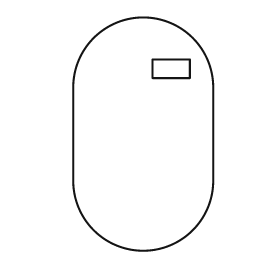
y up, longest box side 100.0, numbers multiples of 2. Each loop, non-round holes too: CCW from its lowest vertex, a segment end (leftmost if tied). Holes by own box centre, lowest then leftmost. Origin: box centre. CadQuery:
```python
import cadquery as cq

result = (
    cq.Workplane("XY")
    .moveTo(-30.0, -20.0)
    .threePointArc((0.0, -50.0), (30.0, -20.0))
    .lineTo(30.0, 20.0)
    .threePointArc((0.0, 50.0), (-30.0, 20.0))
    .close()
    .moveTo(4.0, 24.0)
    .lineTo(20.0, 24.0)
    .lineTo(20.0, 32.0)
    .lineTo(4.0, 32.0)
    .close()
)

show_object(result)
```